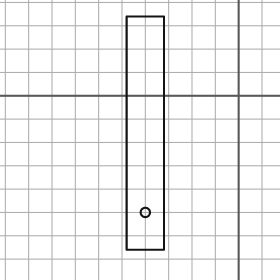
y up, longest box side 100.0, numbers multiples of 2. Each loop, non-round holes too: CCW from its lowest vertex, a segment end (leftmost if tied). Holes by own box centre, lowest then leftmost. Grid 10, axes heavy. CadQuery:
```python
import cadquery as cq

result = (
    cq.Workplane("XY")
    .moveTo(-48.0, -66.0)
    .lineTo(-32.0, -66.0)
    .lineTo(-32.0, 34.0)
    .lineTo(-48.0, 34.0)
    .close()
    .moveTo(-40.0, -50.0)
    .circle(2.0)
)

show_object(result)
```